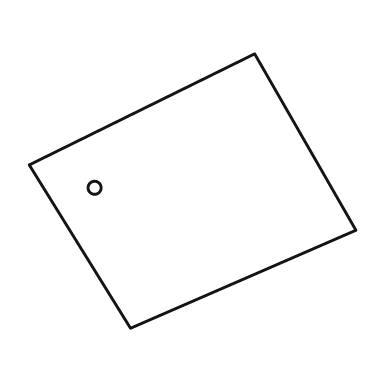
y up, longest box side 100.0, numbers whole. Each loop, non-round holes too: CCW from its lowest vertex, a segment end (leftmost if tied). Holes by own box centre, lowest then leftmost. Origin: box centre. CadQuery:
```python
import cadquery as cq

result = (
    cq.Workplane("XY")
    .moveTo(-19.0, -42.0)
    .lineTo(50.0, -12.0)
    .lineTo(19.0, 42.0)
    .lineTo(-50.0, 8.0)
    .close()
    .moveTo(-30.0, 1.0)
    .circle(2.0)
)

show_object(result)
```